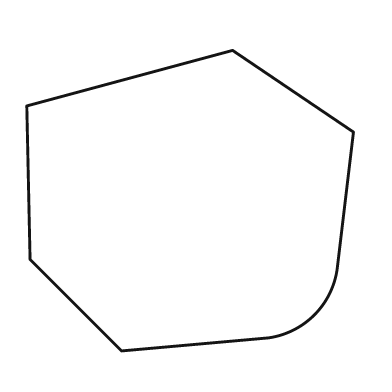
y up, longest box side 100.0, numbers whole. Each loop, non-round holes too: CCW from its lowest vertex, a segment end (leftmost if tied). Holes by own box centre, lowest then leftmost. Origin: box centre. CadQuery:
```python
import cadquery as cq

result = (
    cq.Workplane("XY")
    .moveTo(-21.0, -46.0)
    .lineTo(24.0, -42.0)
    .threePointArc((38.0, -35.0), (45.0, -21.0))
    .lineTo(50.0, 21.0)
    .lineTo(13.0, 46.0)
    .lineTo(-50.0, 29.0)
    .lineTo(-49.0, -18.0)
    .close()
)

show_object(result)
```